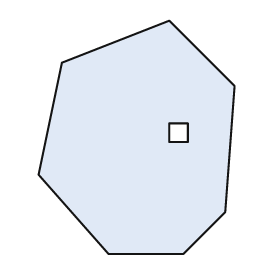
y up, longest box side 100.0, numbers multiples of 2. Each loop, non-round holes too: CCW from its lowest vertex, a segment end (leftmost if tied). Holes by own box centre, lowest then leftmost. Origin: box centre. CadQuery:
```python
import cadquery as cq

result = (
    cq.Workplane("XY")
    .moveTo(-12.0, -50.0)
    .lineTo(20.0, -50.0)
    .lineTo(38.0, -32.0)
    .lineTo(42.0, 22.0)
    .lineTo(14.0, 50.0)
    .lineTo(-32.0, 32.0)
    .lineTo(-42.0, -16.0)
    .close()
    .moveTo(14.0, -2.0)
    .lineTo(22.0, -2.0)
    .lineTo(22.0, 6.0)
    .lineTo(14.0, 6.0)
    .close()
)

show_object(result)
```